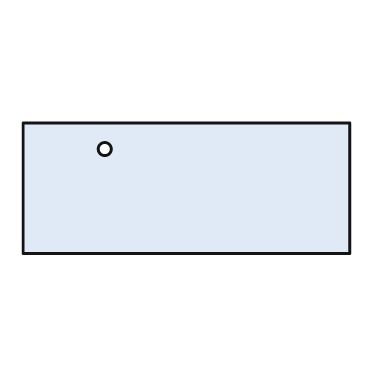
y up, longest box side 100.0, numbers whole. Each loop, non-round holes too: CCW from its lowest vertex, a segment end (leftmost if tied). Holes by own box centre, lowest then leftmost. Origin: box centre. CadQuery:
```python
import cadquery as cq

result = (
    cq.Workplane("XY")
    .moveTo(-50.0, -20.0)
    .lineTo(50.0, -20.0)
    .lineTo(50.0, 20.0)
    .lineTo(-50.0, 20.0)
    .close()
    .moveTo(-25.0, 12.0)
    .circle(2.0)
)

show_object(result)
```